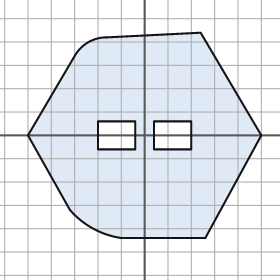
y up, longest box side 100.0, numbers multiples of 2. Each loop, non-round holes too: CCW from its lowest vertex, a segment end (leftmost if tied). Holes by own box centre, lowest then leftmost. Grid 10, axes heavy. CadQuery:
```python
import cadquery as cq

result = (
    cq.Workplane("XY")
    .moveTo(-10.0, -44.0)
    .lineTo(26.0, -44.0)
    .lineTo(50.0, 0.0)
    .lineTo(24.0, 44.0)
    .lineTo(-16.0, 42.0)
    .threePointArc((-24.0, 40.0), (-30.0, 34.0))
    .lineTo(-50.0, 0.0)
    .lineTo(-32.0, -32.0)
    .threePointArc((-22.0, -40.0), (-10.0, -44.0))
    .close()
    .moveTo(-20.0, -6.0)
    .lineTo(-4.0, -6.0)
    .lineTo(-4.0, 6.0)
    .lineTo(-20.0, 6.0)
    .close()
    .moveTo(4.0, -6.0)
    .lineTo(20.0, -6.0)
    .lineTo(20.0, 6.0)
    .lineTo(4.0, 6.0)
    .close()
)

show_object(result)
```